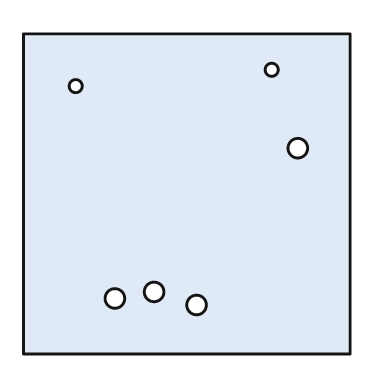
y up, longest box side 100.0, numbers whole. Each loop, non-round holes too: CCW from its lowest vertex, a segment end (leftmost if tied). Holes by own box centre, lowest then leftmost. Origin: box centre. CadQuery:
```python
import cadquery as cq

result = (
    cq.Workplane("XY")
    .moveTo(-50.0, -49.0)
    .lineTo(50.0, -49.0)
    .lineTo(50.0, 49.0)
    .lineTo(-50.0, 49.0)
    .close()
    .moveTo(3.0, -34.0)
    .circle(3.0)
    .moveTo(-22.0, -32.0)
    .circle(3.0)
    .moveTo(-10.0, -30.0)
    .circle(3.0)
    .moveTo(34.0, 14.0)
    .circle(3.0)
    .moveTo(-34.0, 33.0)
    .circle(2.0)
    .moveTo(26.0, 38.0)
    .circle(2.0)
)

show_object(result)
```